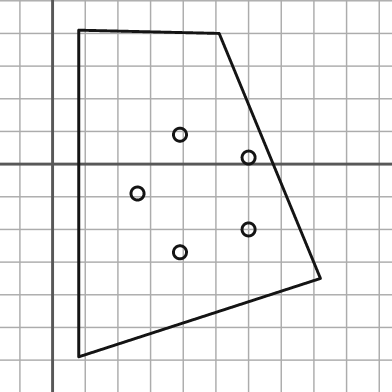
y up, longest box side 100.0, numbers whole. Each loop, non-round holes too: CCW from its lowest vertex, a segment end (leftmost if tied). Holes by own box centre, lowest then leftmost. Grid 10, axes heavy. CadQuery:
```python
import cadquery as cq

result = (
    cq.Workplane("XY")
    .moveTo(8.0, -59.0)
    .lineTo(82.0, -35.0)
    .lineTo(51.0, 40.0)
    .lineTo(8.0, 41.0)
    .close()
    .moveTo(39.0, -27.0)
    .circle(2.0)
    .moveTo(60.0, -20.0)
    .circle(2.0)
    .moveTo(26.0, -9.0)
    .circle(2.0)
    .moveTo(60.0, 2.0)
    .circle(2.0)
    .moveTo(39.0, 9.0)
    .circle(2.0)
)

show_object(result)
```